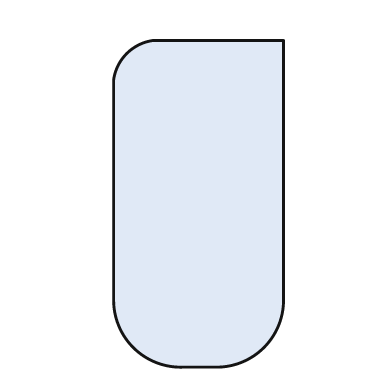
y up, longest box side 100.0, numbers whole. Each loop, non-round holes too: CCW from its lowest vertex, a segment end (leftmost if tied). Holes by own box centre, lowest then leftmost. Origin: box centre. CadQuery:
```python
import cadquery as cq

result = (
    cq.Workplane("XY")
    .moveTo(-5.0, -50.0)
    .lineTo(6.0, -50.0)
    .threePointArc((20.0, -44.0), (26.0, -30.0))
    .lineTo(26.0, 50.0)
    .lineTo(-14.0, 50.0)
    .threePointArc((-22.0, 46.0), (-26.0, 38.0))
    .lineTo(-26.0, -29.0)
    .threePointArc((-20.0, -44.0), (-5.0, -50.0))
    .close()
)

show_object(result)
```